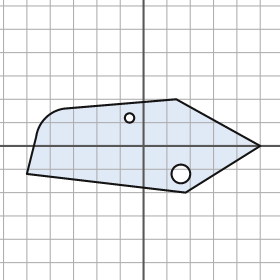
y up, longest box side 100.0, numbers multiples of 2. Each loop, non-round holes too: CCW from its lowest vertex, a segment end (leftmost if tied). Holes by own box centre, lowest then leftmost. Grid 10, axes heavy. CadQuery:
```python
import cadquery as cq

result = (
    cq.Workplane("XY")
    .moveTo(18.0, -20.0)
    .lineTo(50.0, 0.0)
    .lineTo(14.0, 20.0)
    .lineTo(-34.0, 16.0)
    .threePointArc((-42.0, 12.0), (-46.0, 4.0))
    .lineTo(-50.0, -12.0)
    .close()
    .moveTo(16.0, -12.0)
    .circle(4.0)
    .moveTo(-6.0, 12.0)
    .circle(2.0)
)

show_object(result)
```